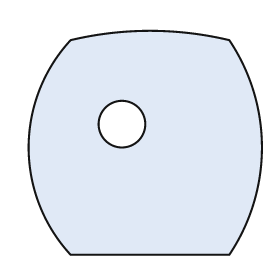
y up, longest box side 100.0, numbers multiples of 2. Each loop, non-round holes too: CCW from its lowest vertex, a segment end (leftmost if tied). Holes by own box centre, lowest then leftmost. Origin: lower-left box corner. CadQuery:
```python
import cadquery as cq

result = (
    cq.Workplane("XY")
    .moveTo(18.0, 0.0)
    .lineTo(86.0, 0.0)
    .threePointArc((100.0, 46.0), (86.0, 92.0))
    .threePointArc((52.0, 96.0), (18.0, 92.0))
    .threePointArc((0.0, 46.0), (18.0, 0.0))
    .close()
    .moveTo(40.0, 56.0)
    .circle(10.0)
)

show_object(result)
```